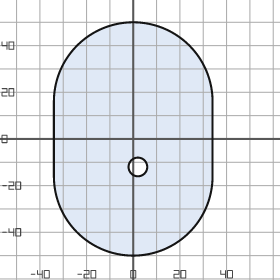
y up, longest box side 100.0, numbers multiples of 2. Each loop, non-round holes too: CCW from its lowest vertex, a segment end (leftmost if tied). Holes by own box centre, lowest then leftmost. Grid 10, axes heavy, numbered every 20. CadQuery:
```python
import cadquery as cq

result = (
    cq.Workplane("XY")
    .moveTo(-34.0, -16.0)
    .threePointArc((0.0, -50.0), (34.0, -16.0))
    .lineTo(34.0, 16.0)
    .threePointArc((0.0, 50.0), (-34.0, 16.0))
    .close()
    .moveTo(2.0, -12.0)
    .circle(4.0)
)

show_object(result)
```